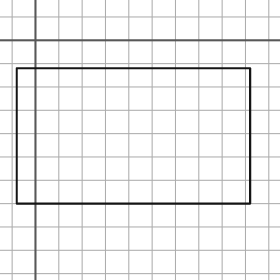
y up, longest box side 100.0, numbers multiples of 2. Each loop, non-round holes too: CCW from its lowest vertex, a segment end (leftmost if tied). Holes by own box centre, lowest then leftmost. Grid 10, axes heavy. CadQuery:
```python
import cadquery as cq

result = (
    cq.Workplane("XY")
    .moveTo(-8.0, -70.0)
    .lineTo(92.0, -70.0)
    .lineTo(92.0, -12.0)
    .lineTo(-8.0, -12.0)
    .close()
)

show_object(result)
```